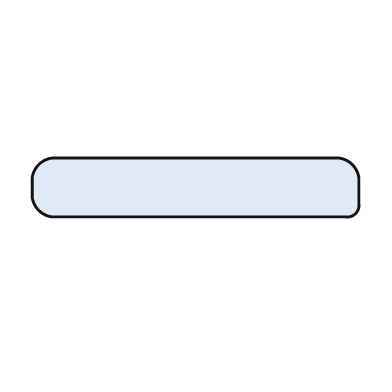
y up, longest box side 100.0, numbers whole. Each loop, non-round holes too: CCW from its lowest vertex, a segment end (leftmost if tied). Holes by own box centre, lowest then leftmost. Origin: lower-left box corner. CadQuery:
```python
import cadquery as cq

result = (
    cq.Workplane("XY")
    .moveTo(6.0, 0.0)
    .lineTo(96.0, 0.0)
    .threePointArc((99.0, 1.0), (100.0, 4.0))
    .lineTo(100.0, 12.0)
    .threePointArc((98.0, 16.0), (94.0, 18.0))
    .lineTo(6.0, 18.0)
    .threePointArc((2.0, 16.0), (0.0, 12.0))
    .lineTo(0.0, 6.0)
    .threePointArc((2.0, 2.0), (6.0, 0.0))
    .close()
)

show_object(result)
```